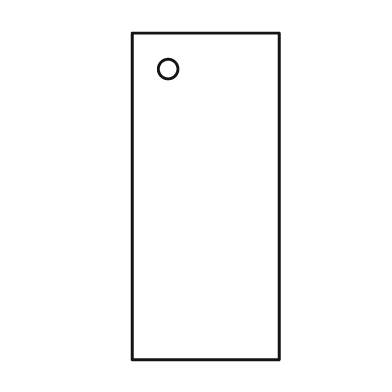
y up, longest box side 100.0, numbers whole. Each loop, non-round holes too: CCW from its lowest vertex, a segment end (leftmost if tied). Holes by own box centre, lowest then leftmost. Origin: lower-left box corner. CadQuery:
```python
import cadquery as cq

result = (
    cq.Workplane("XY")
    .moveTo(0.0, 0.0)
    .lineTo(45.0, 0.0)
    .lineTo(45.0, 100.0)
    .lineTo(0.0, 100.0)
    .close()
    .moveTo(11.0, 89.0)
    .circle(3.0)
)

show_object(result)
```